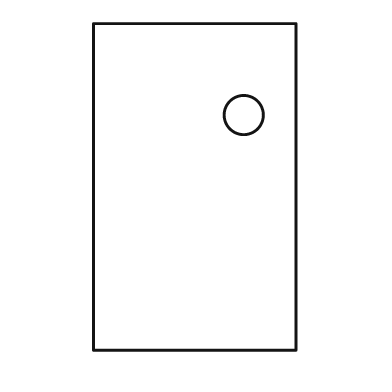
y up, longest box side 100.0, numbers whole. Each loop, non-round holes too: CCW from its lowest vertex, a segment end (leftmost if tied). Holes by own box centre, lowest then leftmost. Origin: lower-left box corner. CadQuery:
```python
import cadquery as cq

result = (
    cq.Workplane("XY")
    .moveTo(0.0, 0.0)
    .lineTo(62.0, 0.0)
    .lineTo(62.0, 100.0)
    .lineTo(0.0, 100.0)
    .close()
    .moveTo(46.0, 72.0)
    .circle(6.0)
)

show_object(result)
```